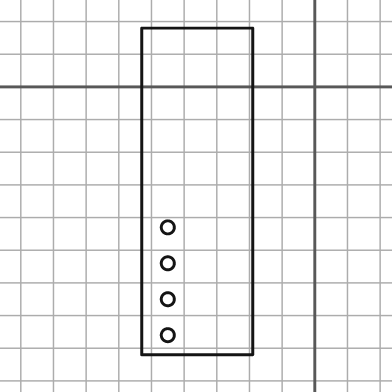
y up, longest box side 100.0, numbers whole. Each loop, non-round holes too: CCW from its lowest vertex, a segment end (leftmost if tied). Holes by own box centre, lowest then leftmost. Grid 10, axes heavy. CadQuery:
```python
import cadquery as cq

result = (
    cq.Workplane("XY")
    .moveTo(-53.0, -82.0)
    .lineTo(-19.0, -82.0)
    .lineTo(-19.0, 18.0)
    .lineTo(-53.0, 18.0)
    .close()
    .moveTo(-45.0, -76.0)
    .circle(2.0)
    .moveTo(-45.0, -65.0)
    .circle(2.0)
    .moveTo(-45.0, -54.0)
    .circle(2.0)
    .moveTo(-45.0, -43.0)
    .circle(2.0)
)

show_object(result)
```